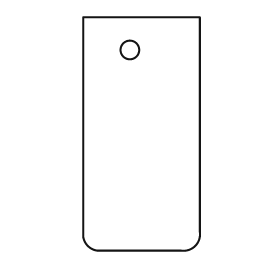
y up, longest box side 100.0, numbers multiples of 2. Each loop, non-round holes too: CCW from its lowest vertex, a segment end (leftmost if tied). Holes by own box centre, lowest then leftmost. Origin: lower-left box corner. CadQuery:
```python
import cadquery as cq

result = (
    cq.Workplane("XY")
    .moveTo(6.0, 0.0)
    .lineTo(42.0, 0.0)
    .threePointArc((48.0, 2.0), (50.0, 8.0))
    .lineTo(50.0, 100.0)
    .lineTo(0.0, 100.0)
    .lineTo(0.0, 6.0)
    .threePointArc((2.0, 2.0), (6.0, 0.0))
    .close()
    .moveTo(20.0, 86.0)
    .circle(4.0)
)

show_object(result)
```